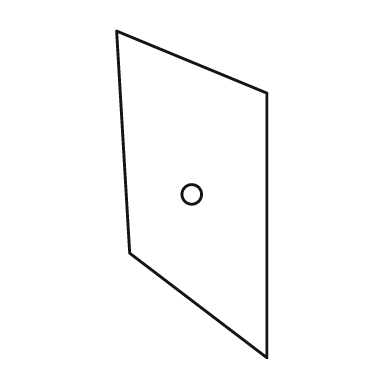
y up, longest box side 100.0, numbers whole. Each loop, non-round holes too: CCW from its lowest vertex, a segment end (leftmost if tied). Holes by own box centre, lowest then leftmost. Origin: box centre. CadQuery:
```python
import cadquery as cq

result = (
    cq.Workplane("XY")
    .moveTo(23.0, -50.0)
    .lineTo(23.0, 31.0)
    .lineTo(-23.0, 50.0)
    .lineTo(-19.0, -18.0)
    .close()
    .moveTo(0.0, 0.0)
    .circle(3.0)
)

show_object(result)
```